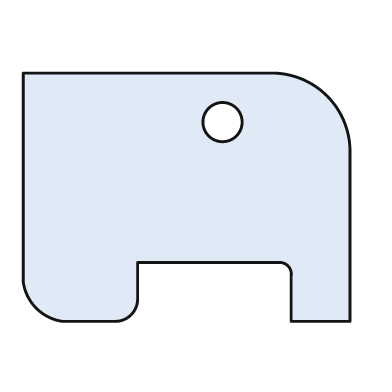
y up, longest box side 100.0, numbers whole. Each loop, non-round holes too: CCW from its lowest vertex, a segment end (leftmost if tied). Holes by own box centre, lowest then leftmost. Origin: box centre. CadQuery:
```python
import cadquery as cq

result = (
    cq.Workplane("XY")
    .moveTo(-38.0, -38.0)
    .lineTo(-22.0, -38.0)
    .threePointArc((-17.0, -36.0), (-15.0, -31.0))
    .lineTo(-15.0, -20.0)
    .lineTo(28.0, -20.0)
    .threePointArc((31.0, -21.0), (32.0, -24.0))
    .lineTo(32.0, -38.0)
    .lineTo(50.0, -38.0)
    .lineTo(50.0, 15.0)
    .threePointArc((43.0, 31.0), (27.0, 38.0))
    .lineTo(-50.0, 38.0)
    .lineTo(-50.0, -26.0)
    .threePointArc((-46.0, -34.0), (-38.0, -38.0))
    .close()
    .moveTo(11.0, 23.0)
    .circle(6.0)
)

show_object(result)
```